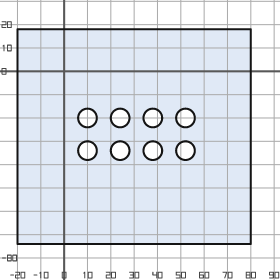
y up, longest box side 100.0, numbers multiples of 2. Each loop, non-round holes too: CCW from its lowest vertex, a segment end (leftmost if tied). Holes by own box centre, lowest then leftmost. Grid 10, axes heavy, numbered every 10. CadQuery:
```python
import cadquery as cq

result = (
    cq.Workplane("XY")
    .moveTo(-20.0, -74.0)
    .lineTo(80.0, -74.0)
    .lineTo(80.0, 18.0)
    .lineTo(-20.0, 18.0)
    .close()
    .moveTo(10.0, -34.0)
    .circle(4.0)
    .moveTo(24.0, -34.0)
    .circle(4.0)
    .moveTo(38.0, -34.0)
    .circle(4.0)
    .moveTo(52.0, -34.0)
    .circle(4.0)
    .moveTo(10.0, -20.0)
    .circle(4.0)
    .moveTo(24.0, -20.0)
    .circle(4.0)
    .moveTo(38.0, -20.0)
    .circle(4.0)
    .moveTo(52.0, -20.0)
    .circle(4.0)
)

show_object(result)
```